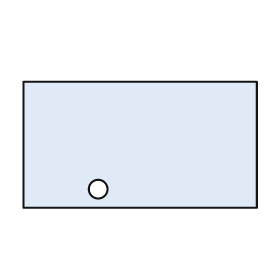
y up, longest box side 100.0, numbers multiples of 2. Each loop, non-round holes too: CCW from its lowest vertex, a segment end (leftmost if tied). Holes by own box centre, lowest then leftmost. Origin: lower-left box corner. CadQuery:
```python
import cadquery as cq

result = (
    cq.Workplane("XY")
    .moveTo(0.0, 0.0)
    .lineTo(100.0, 0.0)
    .lineTo(100.0, 54.0)
    .lineTo(0.0, 54.0)
    .close()
    .moveTo(32.0, 8.0)
    .circle(4.0)
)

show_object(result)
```